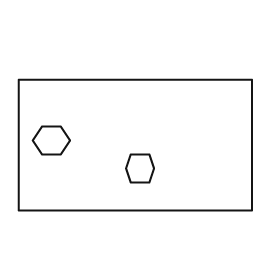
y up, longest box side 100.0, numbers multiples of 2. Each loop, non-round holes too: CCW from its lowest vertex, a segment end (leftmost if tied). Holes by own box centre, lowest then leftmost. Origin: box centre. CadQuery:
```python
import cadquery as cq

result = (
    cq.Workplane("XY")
    .moveTo(-50.0, -28.0)
    .lineTo(50.0, -28.0)
    .lineTo(50.0, 28.0)
    .lineTo(-50.0, 28.0)
    .close()
    .moveTo(-2.0, -16.0)
    .lineTo(6.0, -16.0)
    .lineTo(8.0, -10.0)
    .lineTo(6.0, -4.0)
    .lineTo(-2.0, -4.0)
    .lineTo(-4.0, -10.0)
    .close()
    .moveTo(-40.0, -4.0)
    .lineTo(-32.0, -4.0)
    .lineTo(-28.0, 2.0)
    .lineTo(-32.0, 8.0)
    .lineTo(-40.0, 8.0)
    .lineTo(-44.0, 2.0)
    .close()
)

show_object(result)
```